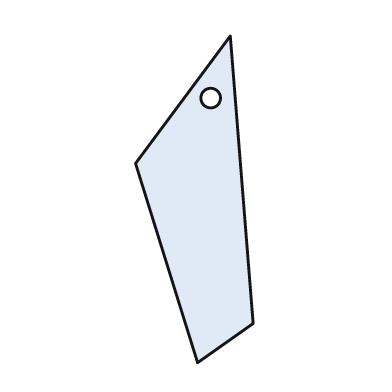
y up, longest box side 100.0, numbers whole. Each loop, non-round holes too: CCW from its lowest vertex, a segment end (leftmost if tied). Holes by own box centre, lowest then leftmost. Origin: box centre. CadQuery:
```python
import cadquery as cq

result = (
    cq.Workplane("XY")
    .moveTo(1.0, -50.0)
    .lineTo(18.0, -38.0)
    .lineTo(11.0, 50.0)
    .lineTo(-18.0, 11.0)
    .close()
    .moveTo(5.0, 31.0)
    .circle(3.0)
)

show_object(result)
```